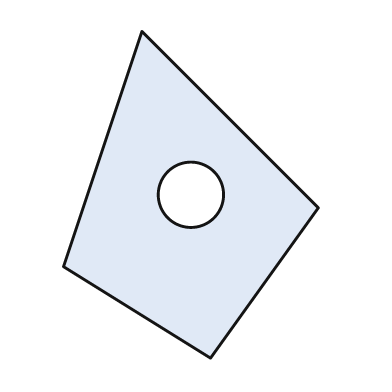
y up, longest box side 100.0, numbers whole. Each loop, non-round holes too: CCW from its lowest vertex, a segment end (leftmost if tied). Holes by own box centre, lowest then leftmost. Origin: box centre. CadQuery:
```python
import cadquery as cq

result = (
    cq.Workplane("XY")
    .moveTo(6.0, -50.0)
    .lineTo(39.0, -4.0)
    .lineTo(-15.0, 50.0)
    .lineTo(-39.0, -22.0)
    .close()
    .moveTo(0.0, 0.0)
    .circle(10.0)
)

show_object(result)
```